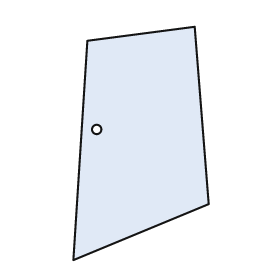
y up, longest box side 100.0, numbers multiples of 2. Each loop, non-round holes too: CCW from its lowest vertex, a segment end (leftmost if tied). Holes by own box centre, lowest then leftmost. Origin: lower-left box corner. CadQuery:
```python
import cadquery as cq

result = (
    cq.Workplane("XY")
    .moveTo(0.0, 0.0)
    .lineTo(58.0, 24.0)
    .lineTo(52.0, 100.0)
    .lineTo(6.0, 94.0)
    .close()
    .moveTo(10.0, 56.0)
    .circle(2.0)
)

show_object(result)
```